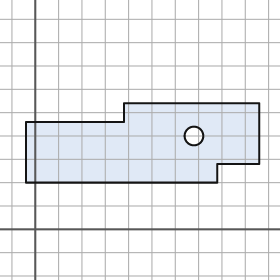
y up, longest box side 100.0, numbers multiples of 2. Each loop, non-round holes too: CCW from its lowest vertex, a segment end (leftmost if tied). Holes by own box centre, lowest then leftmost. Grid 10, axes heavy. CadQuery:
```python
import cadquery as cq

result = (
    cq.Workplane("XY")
    .moveTo(-4.0, 20.0)
    .lineTo(78.0, 20.0)
    .lineTo(78.0, 28.0)
    .lineTo(96.0, 28.0)
    .lineTo(96.0, 54.0)
    .lineTo(38.0, 54.0)
    .lineTo(38.0, 46.0)
    .lineTo(-4.0, 46.0)
    .close()
    .moveTo(68.0, 40.0)
    .circle(4.0)
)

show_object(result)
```